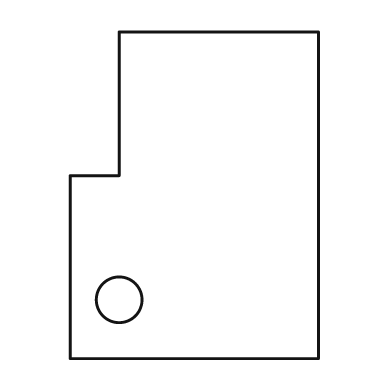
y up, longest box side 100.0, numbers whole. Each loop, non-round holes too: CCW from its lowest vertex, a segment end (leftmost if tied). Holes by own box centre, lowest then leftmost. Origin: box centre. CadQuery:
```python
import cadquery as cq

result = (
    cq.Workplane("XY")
    .moveTo(-38.0, -50.0)
    .lineTo(38.0, -50.0)
    .lineTo(38.0, 50.0)
    .lineTo(-23.0, 50.0)
    .lineTo(-23.0, 6.0)
    .lineTo(-38.0, 6.0)
    .close()
    .moveTo(-23.0, -32.0)
    .circle(7.0)
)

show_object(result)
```